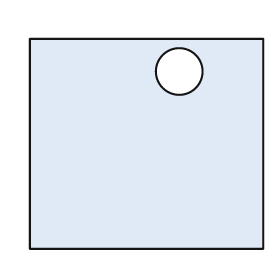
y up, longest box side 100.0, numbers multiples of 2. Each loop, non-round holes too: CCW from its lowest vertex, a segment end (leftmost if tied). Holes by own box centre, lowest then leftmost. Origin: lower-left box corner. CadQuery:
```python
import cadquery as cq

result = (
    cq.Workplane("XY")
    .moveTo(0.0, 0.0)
    .lineTo(100.0, 0.0)
    .lineTo(100.0, 90.0)
    .lineTo(0.0, 90.0)
    .close()
    .moveTo(64.0, 76.0)
    .circle(10.0)
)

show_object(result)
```